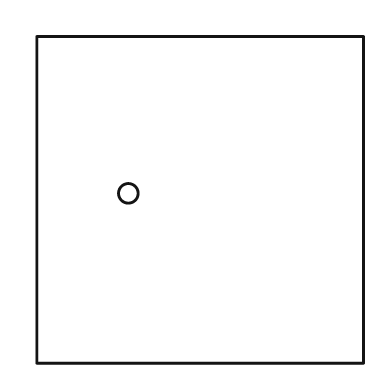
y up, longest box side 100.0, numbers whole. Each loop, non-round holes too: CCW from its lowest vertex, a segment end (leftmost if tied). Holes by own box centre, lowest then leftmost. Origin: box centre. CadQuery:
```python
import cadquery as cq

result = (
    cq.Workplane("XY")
    .moveTo(-50.0, -50.0)
    .lineTo(50.0, -50.0)
    .lineTo(50.0, 50.0)
    .lineTo(-50.0, 50.0)
    .close()
    .moveTo(-22.0, 2.0)
    .circle(3.0)
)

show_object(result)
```